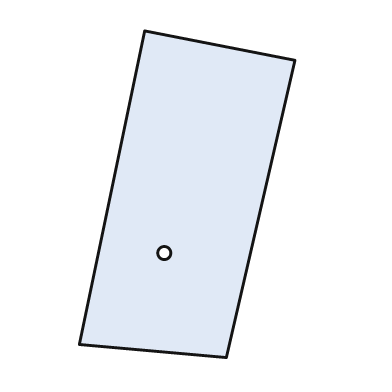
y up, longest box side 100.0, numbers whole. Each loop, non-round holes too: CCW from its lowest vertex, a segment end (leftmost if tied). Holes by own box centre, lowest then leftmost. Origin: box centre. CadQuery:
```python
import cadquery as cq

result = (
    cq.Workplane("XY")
    .moveTo(12.0, -50.0)
    .lineTo(33.0, 41.0)
    .lineTo(-13.0, 50.0)
    .lineTo(-33.0, -46.0)
    .close()
    .moveTo(-7.0, -18.0)
    .circle(2.0)
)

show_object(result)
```